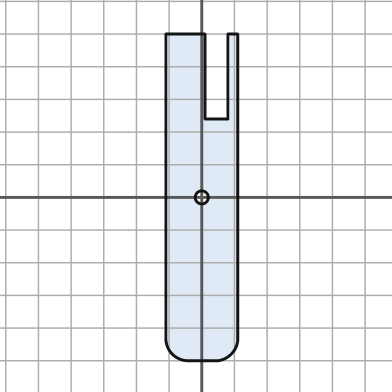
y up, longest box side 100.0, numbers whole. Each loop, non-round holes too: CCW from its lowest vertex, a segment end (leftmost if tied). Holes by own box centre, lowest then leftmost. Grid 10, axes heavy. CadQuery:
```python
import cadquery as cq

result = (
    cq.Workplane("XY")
    .moveTo(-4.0, -50.0)
    .lineTo(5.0, -50.0)
    .threePointArc((9.0, -48.0), (11.0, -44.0))
    .lineTo(11.0, 50.0)
    .lineTo(8.0, 50.0)
    .lineTo(8.0, 24.0)
    .lineTo(1.0, 24.0)
    .lineTo(1.0, 50.0)
    .lineTo(-11.0, 50.0)
    .lineTo(-11.0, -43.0)
    .threePointArc((-9.0, -48.0), (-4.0, -50.0))
    .close()
    .moveTo(0.0, 0.0)
    .circle(2.0)
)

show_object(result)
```